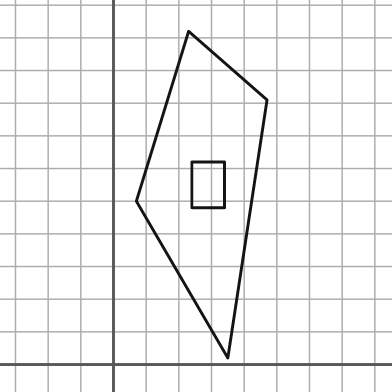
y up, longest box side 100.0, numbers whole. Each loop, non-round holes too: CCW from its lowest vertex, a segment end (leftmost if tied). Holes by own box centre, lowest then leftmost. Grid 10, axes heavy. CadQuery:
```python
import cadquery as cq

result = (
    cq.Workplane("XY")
    .moveTo(35.0, 2.0)
    .lineTo(47.0, 81.0)
    .lineTo(23.0, 102.0)
    .lineTo(7.0, 50.0)
    .close()
    .moveTo(24.0, 48.0)
    .lineTo(34.0, 48.0)
    .lineTo(34.0, 62.0)
    .lineTo(24.0, 62.0)
    .close()
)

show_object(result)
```